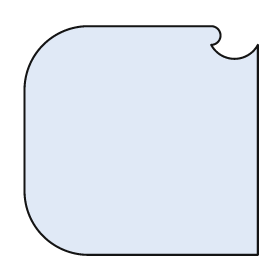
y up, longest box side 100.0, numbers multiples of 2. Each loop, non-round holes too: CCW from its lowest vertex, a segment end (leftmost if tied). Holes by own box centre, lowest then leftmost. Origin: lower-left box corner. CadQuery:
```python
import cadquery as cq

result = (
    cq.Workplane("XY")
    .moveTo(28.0, 0.0)
    .lineTo(100.0, 0.0)
    .lineTo(100.0, 90.0)
    .threePointArc((90.0, 84.0), (80.0, 90.0))
    .threePointArc((84.0, 94.0), (80.0, 98.0))
    .lineTo(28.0, 98.0)
    .threePointArc((8.0, 90.0), (0.0, 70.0))
    .lineTo(0.0, 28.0)
    .threePointArc((8.0, 8.0), (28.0, 0.0))
    .close()
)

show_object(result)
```